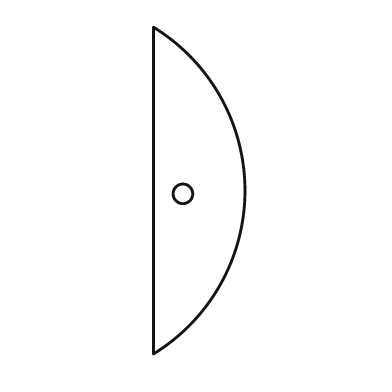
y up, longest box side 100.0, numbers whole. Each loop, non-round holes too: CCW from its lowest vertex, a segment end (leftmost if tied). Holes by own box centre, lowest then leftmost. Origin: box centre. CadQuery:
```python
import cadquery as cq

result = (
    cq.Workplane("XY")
    .moveTo(-14.0, -50.0)
    .threePointArc((14.0, 0.0), (-14.0, 50.0))
    .close()
    .moveTo(-5.0, -1.0)
    .circle(3.0)
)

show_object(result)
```